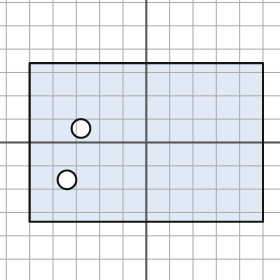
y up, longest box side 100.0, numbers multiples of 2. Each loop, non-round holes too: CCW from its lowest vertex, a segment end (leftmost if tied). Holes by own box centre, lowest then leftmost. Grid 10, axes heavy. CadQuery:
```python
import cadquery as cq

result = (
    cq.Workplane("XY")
    .moveTo(-50.0, -34.0)
    .lineTo(50.0, -34.0)
    .lineTo(50.0, 34.0)
    .lineTo(-50.0, 34.0)
    .close()
    .moveTo(-34.0, -16.0)
    .circle(4.0)
    .moveTo(-28.0, 6.0)
    .circle(4.0)
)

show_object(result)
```